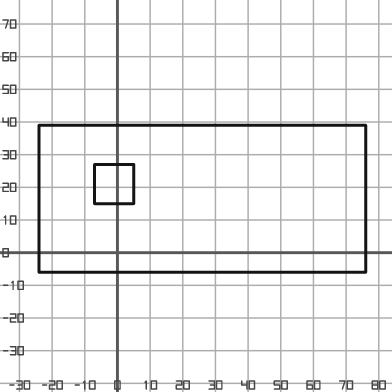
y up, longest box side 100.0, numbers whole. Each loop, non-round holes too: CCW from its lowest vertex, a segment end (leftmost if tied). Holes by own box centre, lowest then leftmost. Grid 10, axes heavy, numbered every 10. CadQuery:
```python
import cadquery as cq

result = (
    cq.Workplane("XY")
    .moveTo(-24.0, -6.0)
    .lineTo(76.0, -6.0)
    .lineTo(76.0, 39.0)
    .lineTo(-24.0, 39.0)
    .close()
    .moveTo(-7.0, 15.0)
    .lineTo(5.0, 15.0)
    .lineTo(5.0, 27.0)
    .lineTo(-7.0, 27.0)
    .close()
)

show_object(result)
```